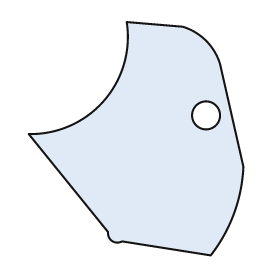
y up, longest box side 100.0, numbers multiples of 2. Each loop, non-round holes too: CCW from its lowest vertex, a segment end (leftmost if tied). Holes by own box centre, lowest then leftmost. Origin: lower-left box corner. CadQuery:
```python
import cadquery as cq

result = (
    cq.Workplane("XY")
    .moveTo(78.0, 0.0)
    .threePointArc((88.0, 18.0), (92.0, 38.0))
    .lineTo(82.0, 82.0)
    .threePointArc((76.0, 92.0), (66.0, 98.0))
    .lineTo(42.0, 100.0)
    .threePointArc((32.0, 66.0), (0.0, 52.0))
    .lineTo(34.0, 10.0)
    .threePointArc((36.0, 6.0), (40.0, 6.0))
    .close()
    .moveTo(76.0, 60.0)
    .circle(6.0)
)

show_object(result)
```